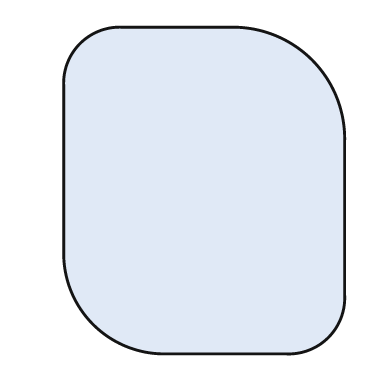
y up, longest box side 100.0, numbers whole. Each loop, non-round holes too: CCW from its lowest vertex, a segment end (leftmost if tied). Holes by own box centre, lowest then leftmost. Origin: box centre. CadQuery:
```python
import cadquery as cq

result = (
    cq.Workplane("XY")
    .moveTo(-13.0, -50.0)
    .lineTo(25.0, -50.0)
    .threePointArc((38.0, -45.0), (43.0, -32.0))
    .lineTo(43.0, 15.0)
    .threePointArc((33.0, 40.0), (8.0, 50.0))
    .lineTo(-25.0, 50.0)
    .threePointArc((-38.0, 45.0), (-43.0, 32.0))
    .lineTo(-43.0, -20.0)
    .threePointArc((-34.0, -41.0), (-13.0, -50.0))
    .close()
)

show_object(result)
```